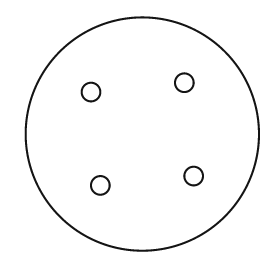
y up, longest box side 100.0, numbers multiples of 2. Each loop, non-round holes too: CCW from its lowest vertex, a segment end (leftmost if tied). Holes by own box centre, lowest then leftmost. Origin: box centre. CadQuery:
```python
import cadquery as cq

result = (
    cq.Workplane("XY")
    .moveTo(0.0, 0.0)
    .circle(50.0)
    .moveTo(-18.0, -22.0)
    .circle(4.0)
    .moveTo(22.0, -18.0)
    .circle(4.0)
    .moveTo(-22.0, 18.0)
    .circle(4.0)
    .moveTo(18.0, 22.0)
    .circle(4.0)
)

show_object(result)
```